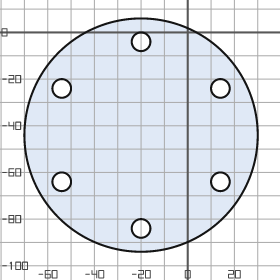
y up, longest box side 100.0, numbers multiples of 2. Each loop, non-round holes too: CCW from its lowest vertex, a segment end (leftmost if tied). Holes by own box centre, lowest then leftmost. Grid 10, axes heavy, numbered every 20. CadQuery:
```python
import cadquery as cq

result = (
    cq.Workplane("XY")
    .moveTo(-20.0, -44.0)
    .circle(50.0)
    .moveTo(-20.0, -84.0)
    .circle(4.0)
    .moveTo(-54.0, -64.0)
    .circle(4.0)
    .moveTo(14.0, -64.0)
    .circle(4.0)
    .moveTo(-54.0, -24.0)
    .circle(4.0)
    .moveTo(14.0, -24.0)
    .circle(4.0)
    .moveTo(-20.0, -4.0)
    .circle(4.0)
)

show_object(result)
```